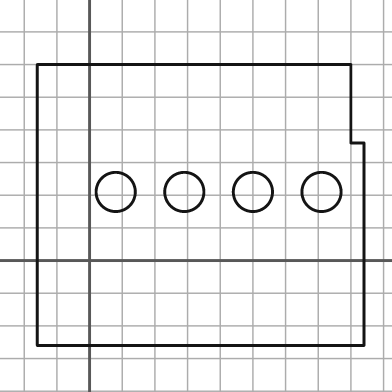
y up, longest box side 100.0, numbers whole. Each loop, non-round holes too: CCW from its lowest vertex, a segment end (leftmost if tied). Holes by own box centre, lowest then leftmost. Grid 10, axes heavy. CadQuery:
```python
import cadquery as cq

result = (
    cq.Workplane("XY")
    .moveTo(-16.0, -26.0)
    .lineTo(84.0, -26.0)
    .lineTo(84.0, 36.0)
    .lineTo(80.0, 36.0)
    .lineTo(80.0, 60.0)
    .lineTo(-16.0, 60.0)
    .close()
    .moveTo(8.0, 21.0)
    .circle(6.0)
    .moveTo(29.0, 21.0)
    .circle(6.0)
    .moveTo(50.0, 21.0)
    .circle(6.0)
    .moveTo(71.0, 21.0)
    .circle(6.0)
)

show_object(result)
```